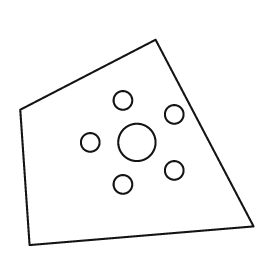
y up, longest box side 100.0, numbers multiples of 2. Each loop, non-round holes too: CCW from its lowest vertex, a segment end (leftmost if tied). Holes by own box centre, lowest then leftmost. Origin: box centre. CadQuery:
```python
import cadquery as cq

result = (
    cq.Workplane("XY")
    .moveTo(-46.0, -44.0)
    .lineTo(50.0, -36.0)
    .lineTo(8.0, 44.0)
    .lineTo(-50.0, 14.0)
    .close()
    .moveTo(-6.0, -18.0)
    .circle(4.0)
    .moveTo(16.0, -12.0)
    .circle(4.0)
    .moveTo(-20.0, 0.0)
    .circle(4.0)
    .moveTo(0.0, 0.0)
    .circle(8.0)
    .moveTo(16.0, 12.0)
    .circle(4.0)
    .moveTo(-6.0, 18.0)
    .circle(4.0)
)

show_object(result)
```